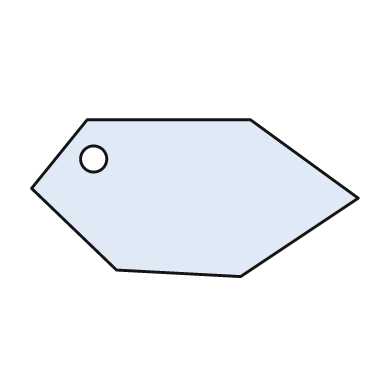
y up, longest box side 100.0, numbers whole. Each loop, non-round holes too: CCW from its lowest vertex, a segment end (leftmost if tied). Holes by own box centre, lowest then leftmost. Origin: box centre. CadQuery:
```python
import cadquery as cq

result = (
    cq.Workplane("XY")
    .moveTo(14.0, -24.0)
    .lineTo(50.0, 0.0)
    .lineTo(17.0, 24.0)
    .lineTo(-33.0, 24.0)
    .lineTo(-50.0, 3.0)
    .lineTo(-24.0, -22.0)
    .close()
    .moveTo(-31.0, 12.0)
    .circle(4.0)
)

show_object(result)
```